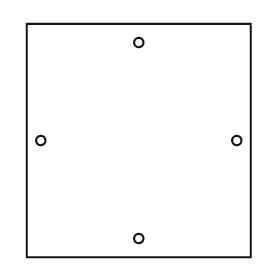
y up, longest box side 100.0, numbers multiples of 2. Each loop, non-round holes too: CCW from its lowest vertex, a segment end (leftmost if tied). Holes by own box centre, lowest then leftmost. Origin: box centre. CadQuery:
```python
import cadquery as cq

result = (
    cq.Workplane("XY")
    .moveTo(-48.0, -50.0)
    .lineTo(48.0, -50.0)
    .lineTo(48.0, 50.0)
    .lineTo(-48.0, 50.0)
    .close()
    .moveTo(0.0, -42.0)
    .circle(2.0)
    .moveTo(-42.0, 0.0)
    .circle(2.0)
    .moveTo(42.0, 0.0)
    .circle(2.0)
    .moveTo(0.0, 42.0)
    .circle(2.0)
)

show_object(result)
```